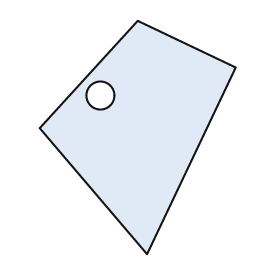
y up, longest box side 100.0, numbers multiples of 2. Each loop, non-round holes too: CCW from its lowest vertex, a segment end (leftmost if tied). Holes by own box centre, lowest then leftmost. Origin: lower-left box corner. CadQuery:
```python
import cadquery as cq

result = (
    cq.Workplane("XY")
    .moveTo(46.0, 0.0)
    .lineTo(84.0, 80.0)
    .lineTo(42.0, 100.0)
    .lineTo(0.0, 54.0)
    .close()
    .moveTo(26.0, 68.0)
    .circle(6.0)
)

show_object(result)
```